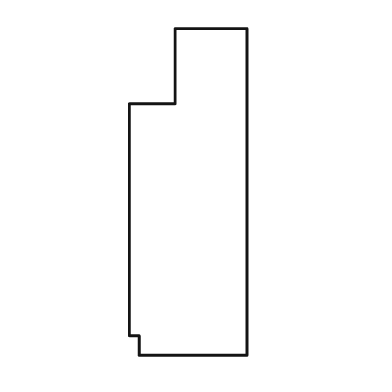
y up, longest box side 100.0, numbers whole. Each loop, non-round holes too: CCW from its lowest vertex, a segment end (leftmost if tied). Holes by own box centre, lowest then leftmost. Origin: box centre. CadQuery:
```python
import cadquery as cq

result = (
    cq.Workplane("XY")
    .moveTo(-15.0, -50.0)
    .lineTo(18.0, -50.0)
    .lineTo(18.0, 50.0)
    .lineTo(-4.0, 50.0)
    .lineTo(-4.0, 27.0)
    .lineTo(-18.0, 27.0)
    .lineTo(-18.0, -44.0)
    .lineTo(-15.0, -44.0)
    .close()
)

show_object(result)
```